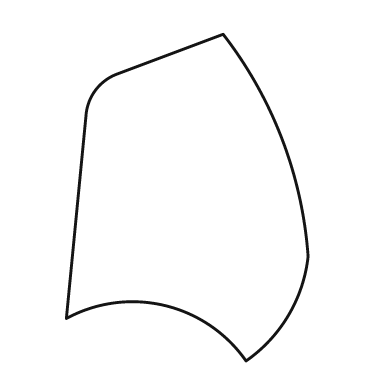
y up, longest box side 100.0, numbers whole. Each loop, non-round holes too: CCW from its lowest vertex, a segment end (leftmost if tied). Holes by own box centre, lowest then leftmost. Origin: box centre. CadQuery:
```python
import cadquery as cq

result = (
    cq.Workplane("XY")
    .moveTo(18.0, -50.0)
    .threePointArc((31.0, -36.0), (37.0, -18.0))
    .threePointArc((29.0, 18.0), (11.0, 50.0))
    .lineTo(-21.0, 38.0)
    .threePointArc((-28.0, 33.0), (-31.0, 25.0))
    .lineTo(-37.0, -37.0)
    .threePointArc((-7.0, -33.0), (18.0, -50.0))
    .close()
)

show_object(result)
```